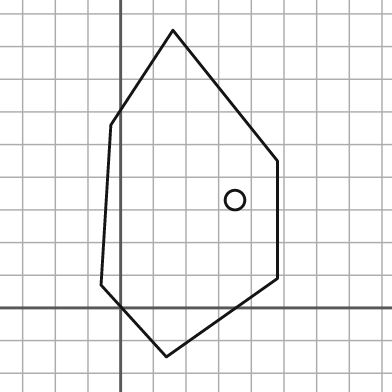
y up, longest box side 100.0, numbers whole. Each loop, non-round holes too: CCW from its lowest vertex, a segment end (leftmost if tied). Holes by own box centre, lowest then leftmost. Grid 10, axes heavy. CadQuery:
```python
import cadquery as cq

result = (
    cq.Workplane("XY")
    .moveTo(14.0, -15.0)
    .lineTo(48.0, 9.0)
    .lineTo(48.0, 45.0)
    .lineTo(16.0, 85.0)
    .lineTo(-3.0, 56.0)
    .lineTo(-6.0, 7.0)
    .close()
    .moveTo(35.0, 33.0)
    .circle(3.0)
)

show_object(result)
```